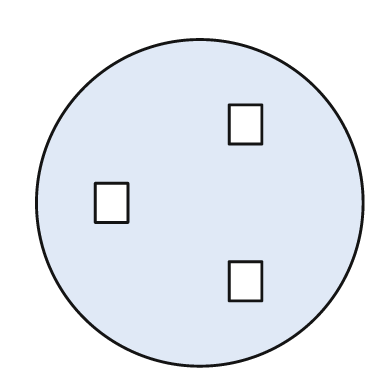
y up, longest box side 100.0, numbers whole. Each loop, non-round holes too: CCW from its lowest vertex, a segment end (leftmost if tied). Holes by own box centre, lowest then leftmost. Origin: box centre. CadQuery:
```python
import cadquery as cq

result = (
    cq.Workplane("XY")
    .moveTo(0.0, 0.0)
    .circle(50.0)
    .moveTo(9.0, -30.0)
    .lineTo(19.0, -30.0)
    .lineTo(19.0, -18.0)
    .lineTo(9.0, -18.0)
    .close()
    .moveTo(-32.0, -6.0)
    .lineTo(-22.0, -6.0)
    .lineTo(-22.0, 6.0)
    .lineTo(-32.0, 6.0)
    .close()
    .moveTo(9.0, 18.0)
    .lineTo(19.0, 18.0)
    .lineTo(19.0, 30.0)
    .lineTo(9.0, 30.0)
    .close()
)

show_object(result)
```